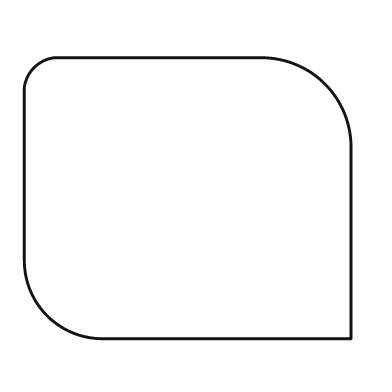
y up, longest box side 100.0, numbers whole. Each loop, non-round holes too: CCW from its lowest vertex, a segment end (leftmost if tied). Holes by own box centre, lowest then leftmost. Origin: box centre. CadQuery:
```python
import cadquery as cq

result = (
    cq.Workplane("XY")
    .moveTo(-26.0, -43.0)
    .lineTo(50.0, -43.0)
    .lineTo(50.0, 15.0)
    .threePointArc((42.0, 35.0), (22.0, 43.0))
    .lineTo(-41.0, 43.0)
    .threePointArc((-47.0, 40.0), (-50.0, 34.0))
    .lineTo(-50.0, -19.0)
    .threePointArc((-43.0, -36.0), (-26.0, -43.0))
    .close()
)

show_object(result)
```